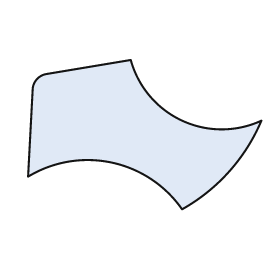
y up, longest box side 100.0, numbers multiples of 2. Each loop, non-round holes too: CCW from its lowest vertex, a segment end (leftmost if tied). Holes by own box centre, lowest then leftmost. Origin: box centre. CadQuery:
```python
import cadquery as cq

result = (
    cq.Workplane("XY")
    .moveTo(16.0, -32.0)
    .threePointArc((36.0, -16.0), (50.0, 6.0))
    .threePointArc((16.0, 6.0), (-6.0, 32.0))
    .lineTo(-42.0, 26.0)
    .threePointArc((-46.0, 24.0), (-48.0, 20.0))
    .lineTo(-50.0, -18.0)
    .threePointArc((-14.0, -12.0), (16.0, -32.0))
    .close()
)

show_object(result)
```